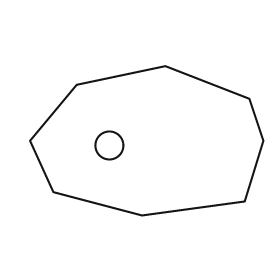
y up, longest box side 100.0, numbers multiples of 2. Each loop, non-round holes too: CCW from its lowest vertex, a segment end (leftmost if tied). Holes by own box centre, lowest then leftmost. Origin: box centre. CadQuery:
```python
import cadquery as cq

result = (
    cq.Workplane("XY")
    .moveTo(-2.0, -32.0)
    .lineTo(42.0, -26.0)
    .lineTo(50.0, 0.0)
    .lineTo(44.0, 18.0)
    .lineTo(8.0, 32.0)
    .lineTo(-30.0, 24.0)
    .lineTo(-50.0, 0.0)
    .lineTo(-40.0, -22.0)
    .close()
    .moveTo(-16.0, -2.0)
    .circle(6.0)
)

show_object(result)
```